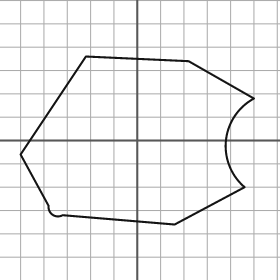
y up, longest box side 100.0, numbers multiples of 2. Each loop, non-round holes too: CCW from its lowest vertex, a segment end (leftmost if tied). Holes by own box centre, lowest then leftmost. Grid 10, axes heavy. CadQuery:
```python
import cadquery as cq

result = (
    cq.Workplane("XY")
    .moveTo(16.0, -36.0)
    .lineTo(46.0, -20.0)
    .threePointArc((38.0, 0.0), (50.0, 18.0))
    .lineTo(22.0, 34.0)
    .lineTo(-22.0, 36.0)
    .lineTo(-50.0, -6.0)
    .lineTo(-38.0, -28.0)
    .threePointArc((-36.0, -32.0), (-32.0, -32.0))
    .close()
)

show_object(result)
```